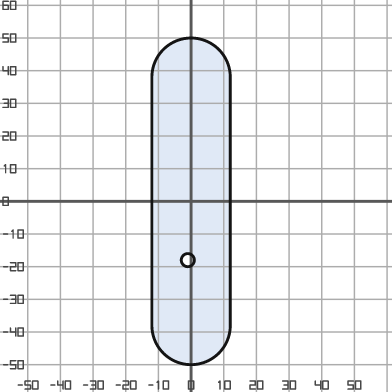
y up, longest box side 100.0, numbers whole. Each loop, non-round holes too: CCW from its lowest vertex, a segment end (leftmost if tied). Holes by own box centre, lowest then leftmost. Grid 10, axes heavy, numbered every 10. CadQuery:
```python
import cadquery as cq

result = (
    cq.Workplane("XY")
    .moveTo(-12.0, -38.0)
    .threePointArc((0.0, -50.0), (12.0, -38.0))
    .lineTo(12.0, 38.0)
    .threePointArc((0.0, 50.0), (-12.0, 38.0))
    .close()
    .moveTo(-1.0, -18.0)
    .circle(2.0)
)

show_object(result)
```